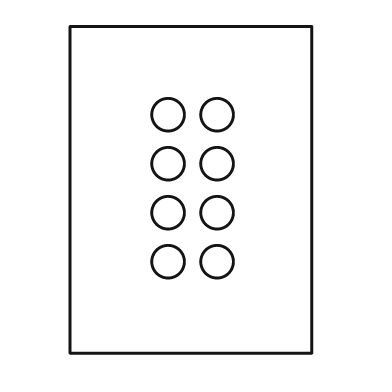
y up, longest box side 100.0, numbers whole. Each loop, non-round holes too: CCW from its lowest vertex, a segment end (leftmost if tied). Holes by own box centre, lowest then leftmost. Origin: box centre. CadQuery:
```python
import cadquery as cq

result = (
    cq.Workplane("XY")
    .moveTo(-37.0, -50.0)
    .lineTo(37.0, -50.0)
    .lineTo(37.0, 50.0)
    .lineTo(-37.0, 50.0)
    .close()
    .moveTo(-7.0, -22.0)
    .circle(5.0)
    .moveTo(8.0, -22.0)
    .circle(5.0)
    .moveTo(-7.0, -7.0)
    .circle(5.0)
    .moveTo(8.0, -7.0)
    .circle(5.0)
    .moveTo(-7.0, 8.0)
    .circle(5.0)
    .moveTo(8.0, 8.0)
    .circle(5.0)
    .moveTo(-7.0, 23.0)
    .circle(5.0)
    .moveTo(8.0, 23.0)
    .circle(5.0)
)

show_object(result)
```